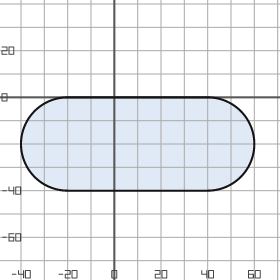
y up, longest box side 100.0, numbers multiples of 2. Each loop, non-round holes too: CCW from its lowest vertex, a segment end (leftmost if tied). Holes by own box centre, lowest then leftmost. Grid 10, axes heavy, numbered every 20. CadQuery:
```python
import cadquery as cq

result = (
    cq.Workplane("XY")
    .moveTo(-20.0, -40.0)
    .lineTo(40.0, -40.0)
    .threePointArc((60.0, -20.0), (40.0, 0.0))
    .lineTo(-20.0, 0.0)
    .threePointArc((-40.0, -20.0), (-20.0, -40.0))
    .close()
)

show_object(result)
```